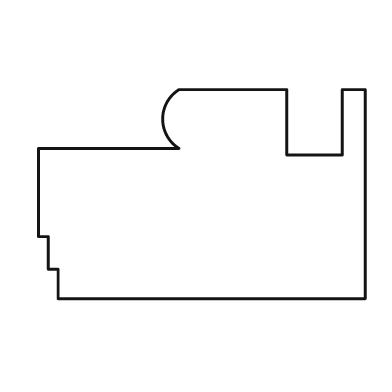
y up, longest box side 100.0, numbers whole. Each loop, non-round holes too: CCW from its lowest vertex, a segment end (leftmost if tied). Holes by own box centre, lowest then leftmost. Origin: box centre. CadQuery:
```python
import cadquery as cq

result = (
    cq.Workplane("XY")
    .moveTo(-44.0, -32.0)
    .lineTo(50.0, -32.0)
    .lineTo(50.0, 32.0)
    .lineTo(43.0, 32.0)
    .lineTo(43.0, 12.0)
    .lineTo(26.0, 12.0)
    .lineTo(26.0, 32.0)
    .lineTo(-7.0, 32.0)
    .threePointArc((-12.0, 23.0), (-7.0, 14.0))
    .lineTo(-50.0, 14.0)
    .lineTo(-50.0, -13.0)
    .lineTo(-47.0, -13.0)
    .lineTo(-47.0, -23.0)
    .lineTo(-44.0, -23.0)
    .close()
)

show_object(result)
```